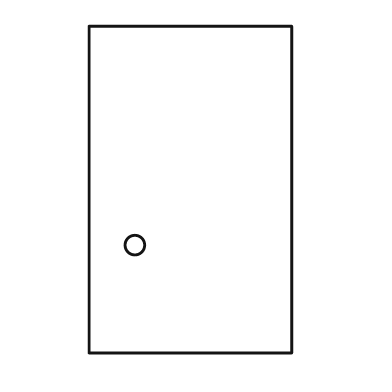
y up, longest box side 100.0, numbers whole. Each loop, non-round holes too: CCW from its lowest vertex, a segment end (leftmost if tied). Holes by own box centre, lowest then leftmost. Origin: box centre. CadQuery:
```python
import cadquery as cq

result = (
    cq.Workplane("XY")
    .moveTo(-31.0, -50.0)
    .lineTo(31.0, -50.0)
    .lineTo(31.0, 50.0)
    .lineTo(-31.0, 50.0)
    .close()
    .moveTo(-17.0, -17.0)
    .circle(3.0)
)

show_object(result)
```